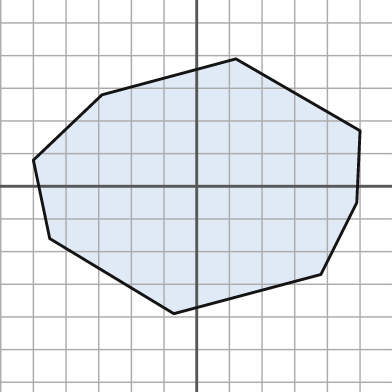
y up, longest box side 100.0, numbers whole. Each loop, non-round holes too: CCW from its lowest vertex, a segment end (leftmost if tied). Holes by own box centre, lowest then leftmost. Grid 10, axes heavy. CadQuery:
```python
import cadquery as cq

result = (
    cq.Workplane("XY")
    .moveTo(-7.0, -39.0)
    .lineTo(38.0, -27.0)
    .lineTo(49.0, -5.0)
    .lineTo(50.0, 17.0)
    .lineTo(12.0, 39.0)
    .lineTo(-29.0, 28.0)
    .lineTo(-50.0, 8.0)
    .lineTo(-45.0, -16.0)
    .close()
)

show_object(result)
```